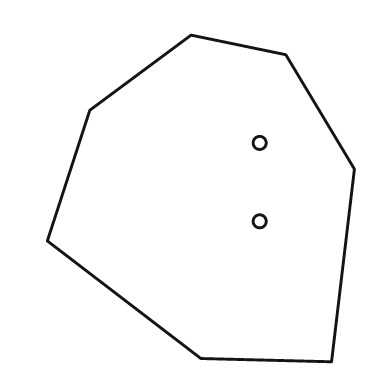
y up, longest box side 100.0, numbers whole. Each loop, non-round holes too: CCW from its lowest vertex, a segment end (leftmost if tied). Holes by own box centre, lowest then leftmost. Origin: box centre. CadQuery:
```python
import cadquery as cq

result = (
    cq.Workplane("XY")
    .moveTo(40.0, -50.0)
    .lineTo(47.0, 9.0)
    .lineTo(26.0, 44.0)
    .lineTo(-3.0, 50.0)
    .lineTo(-34.0, 27.0)
    .lineTo(-47.0, -13.0)
    .lineTo(0.0, -49.0)
    .close()
    .moveTo(18.0, -7.0)
    .circle(2.0)
    .moveTo(18.0, 17.0)
    .circle(2.0)
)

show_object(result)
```